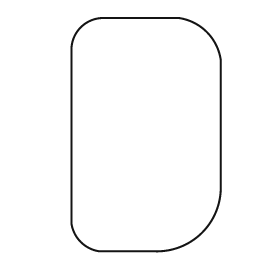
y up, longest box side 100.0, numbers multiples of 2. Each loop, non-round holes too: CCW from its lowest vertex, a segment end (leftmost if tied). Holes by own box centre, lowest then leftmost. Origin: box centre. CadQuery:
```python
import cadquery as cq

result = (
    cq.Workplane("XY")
    .moveTo(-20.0, -50.0)
    .lineTo(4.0, -50.0)
    .threePointArc((24.0, -42.0), (32.0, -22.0))
    .lineTo(32.0, 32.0)
    .threePointArc((26.0, 44.0), (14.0, 50.0))
    .lineTo(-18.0, 50.0)
    .threePointArc((-28.0, 46.0), (-32.0, 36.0))
    .lineTo(-32.0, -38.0)
    .threePointArc((-28.0, -46.0), (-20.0, -50.0))
    .close()
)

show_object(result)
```